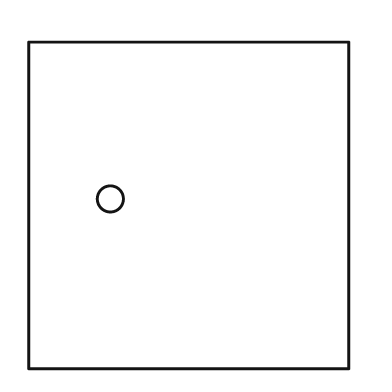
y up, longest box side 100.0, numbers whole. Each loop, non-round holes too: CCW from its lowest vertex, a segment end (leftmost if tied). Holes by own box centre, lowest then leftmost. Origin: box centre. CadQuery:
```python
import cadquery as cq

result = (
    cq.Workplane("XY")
    .moveTo(-49.0, -50.0)
    .lineTo(49.0, -50.0)
    .lineTo(49.0, 50.0)
    .lineTo(-49.0, 50.0)
    .close()
    .moveTo(-24.0, 2.0)
    .circle(4.0)
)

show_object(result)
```